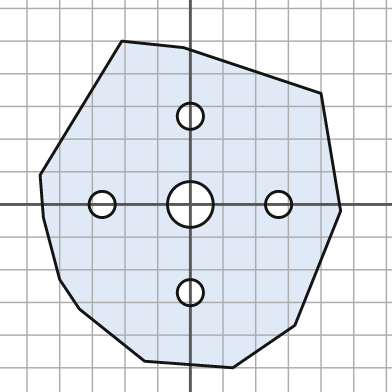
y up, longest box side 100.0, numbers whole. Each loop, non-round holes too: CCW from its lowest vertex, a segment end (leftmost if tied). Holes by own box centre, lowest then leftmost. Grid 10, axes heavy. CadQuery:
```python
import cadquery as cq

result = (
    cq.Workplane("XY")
    .moveTo(13.0, -50.0)
    .lineTo(32.0, -37.0)
    .lineTo(46.0, -2.0)
    .lineTo(40.0, 34.0)
    .lineTo(-2.0, 48.0)
    .lineTo(-21.0, 50.0)
    .lineTo(-46.0, 9.0)
    .lineTo(-45.0, -4.0)
    .lineTo(-40.0, -23.0)
    .lineTo(-34.0, -32.0)
    .lineTo(-14.0, -48.0)
    .close()
    .moveTo(0.0, -27.0)
    .circle(4.0)
    .moveTo(-27.0, 0.0)
    .circle(4.0)
    .moveTo(0.0, 0.0)
    .circle(7.0)
    .moveTo(27.0, 0.0)
    .circle(4.0)
    .moveTo(0.0, 27.0)
    .circle(4.0)
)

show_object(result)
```